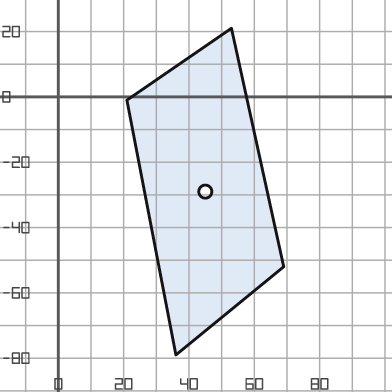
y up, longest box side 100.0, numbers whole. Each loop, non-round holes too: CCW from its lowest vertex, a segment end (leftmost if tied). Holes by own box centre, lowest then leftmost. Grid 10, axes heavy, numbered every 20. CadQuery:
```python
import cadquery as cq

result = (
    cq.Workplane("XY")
    .moveTo(36.0, -79.0)
    .lineTo(69.0, -52.0)
    .lineTo(53.0, 21.0)
    .lineTo(21.0, -1.0)
    .close()
    .moveTo(45.0, -29.0)
    .circle(2.0)
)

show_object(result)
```